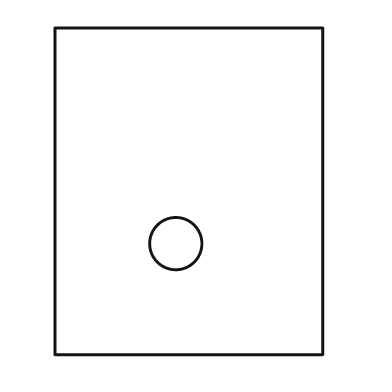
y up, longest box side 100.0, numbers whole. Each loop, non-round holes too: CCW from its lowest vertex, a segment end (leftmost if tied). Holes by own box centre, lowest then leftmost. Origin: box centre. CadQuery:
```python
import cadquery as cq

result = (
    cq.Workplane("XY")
    .moveTo(-41.0, -50.0)
    .lineTo(41.0, -50.0)
    .lineTo(41.0, 50.0)
    .lineTo(-41.0, 50.0)
    .close()
    .moveTo(-4.0, -16.0)
    .circle(8.0)
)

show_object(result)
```